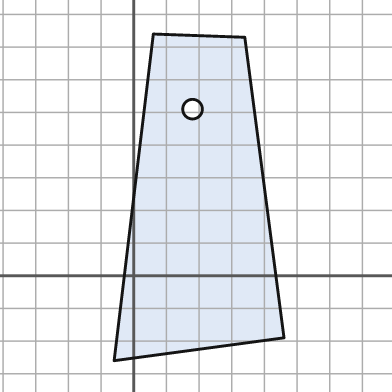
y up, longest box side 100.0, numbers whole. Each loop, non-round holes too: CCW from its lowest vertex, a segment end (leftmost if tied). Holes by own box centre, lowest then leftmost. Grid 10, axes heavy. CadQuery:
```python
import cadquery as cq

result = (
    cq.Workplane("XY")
    .moveTo(-6.0, -26.0)
    .lineTo(46.0, -19.0)
    .lineTo(34.0, 73.0)
    .lineTo(6.0, 74.0)
    .close()
    .moveTo(18.0, 51.0)
    .circle(3.0)
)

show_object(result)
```